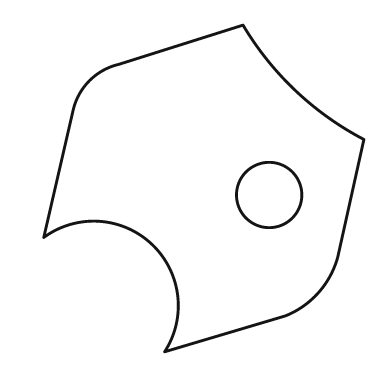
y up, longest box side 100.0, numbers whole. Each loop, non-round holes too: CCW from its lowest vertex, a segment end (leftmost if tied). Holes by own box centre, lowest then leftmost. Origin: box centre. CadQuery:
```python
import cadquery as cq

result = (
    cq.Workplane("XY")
    .moveTo(-12.0, -50.0)
    .lineTo(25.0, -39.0)
    .threePointArc((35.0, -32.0), (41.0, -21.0))
    .lineTo(49.0, 15.0)
    .threePointArc((28.0, 30.0), (12.0, 50.0))
    .lineTo(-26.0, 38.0)
    .threePointArc((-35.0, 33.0), (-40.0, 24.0))
    .lineTo(-49.0, -15.0)
    .threePointArc((-16.0, -17.0), (-12.0, -50.0))
    .close()
    .moveTo(20.0, -2.0)
    .circle(10.0)
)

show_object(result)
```